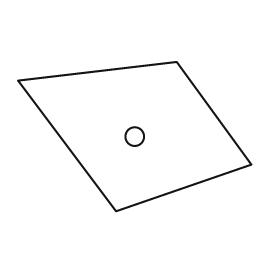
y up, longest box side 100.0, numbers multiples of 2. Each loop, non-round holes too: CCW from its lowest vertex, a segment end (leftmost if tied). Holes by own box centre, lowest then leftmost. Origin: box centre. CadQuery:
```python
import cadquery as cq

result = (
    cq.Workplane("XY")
    .moveTo(-8.0, -32.0)
    .lineTo(50.0, -12.0)
    .lineTo(18.0, 32.0)
    .lineTo(-50.0, 24.0)
    .close()
    .moveTo(0.0, 0.0)
    .circle(4.0)
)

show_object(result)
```